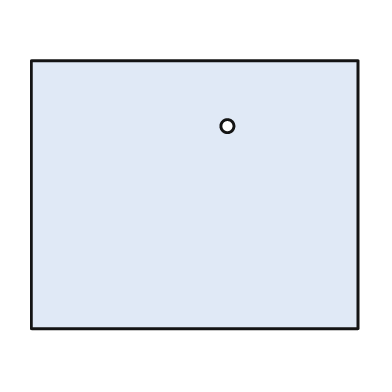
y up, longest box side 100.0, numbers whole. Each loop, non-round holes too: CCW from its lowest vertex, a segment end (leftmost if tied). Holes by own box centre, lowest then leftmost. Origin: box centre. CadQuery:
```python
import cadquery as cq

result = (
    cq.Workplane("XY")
    .moveTo(-50.0, -41.0)
    .lineTo(50.0, -41.0)
    .lineTo(50.0, 41.0)
    .lineTo(-50.0, 41.0)
    .close()
    .moveTo(10.0, 21.0)
    .circle(2.0)
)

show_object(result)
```